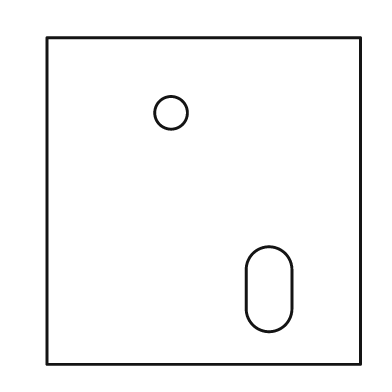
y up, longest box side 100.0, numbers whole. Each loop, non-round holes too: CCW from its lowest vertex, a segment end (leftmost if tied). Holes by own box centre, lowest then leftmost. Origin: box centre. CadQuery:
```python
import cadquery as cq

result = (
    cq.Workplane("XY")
    .moveTo(-48.0, -50.0)
    .lineTo(48.0, -50.0)
    .lineTo(48.0, 50.0)
    .lineTo(-48.0, 50.0)
    .close()
    .moveTo(13.0, -33.0)
    .threePointArc((20.0, -40.0), (27.0, -33.0))
    .lineTo(27.0, -21.0)
    .threePointArc((20.0, -14.0), (13.0, -21.0))
    .close()
    .moveTo(-10.0, 27.0)
    .circle(5.0)
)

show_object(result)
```